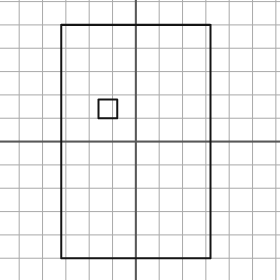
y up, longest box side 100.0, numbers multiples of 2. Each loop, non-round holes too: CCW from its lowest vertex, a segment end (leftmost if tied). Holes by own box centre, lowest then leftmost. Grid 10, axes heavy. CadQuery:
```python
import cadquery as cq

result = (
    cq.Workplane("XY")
    .moveTo(-32.0, -50.0)
    .lineTo(32.0, -50.0)
    .lineTo(32.0, 50.0)
    .lineTo(-32.0, 50.0)
    .close()
    .moveTo(-16.0, 10.0)
    .lineTo(-8.0, 10.0)
    .lineTo(-8.0, 18.0)
    .lineTo(-16.0, 18.0)
    .close()
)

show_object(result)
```